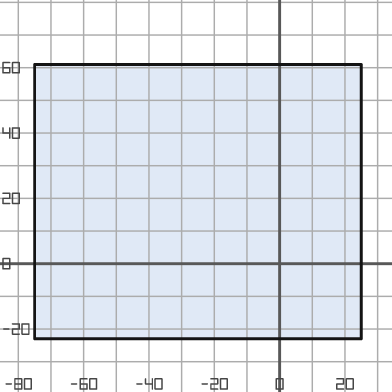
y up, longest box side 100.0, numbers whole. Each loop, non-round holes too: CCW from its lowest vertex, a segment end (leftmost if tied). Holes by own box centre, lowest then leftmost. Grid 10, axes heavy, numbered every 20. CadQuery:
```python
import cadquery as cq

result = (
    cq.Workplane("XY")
    .moveTo(-75.0, -23.0)
    .lineTo(25.0, -23.0)
    .lineTo(25.0, 61.0)
    .lineTo(-75.0, 61.0)
    .close()
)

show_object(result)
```